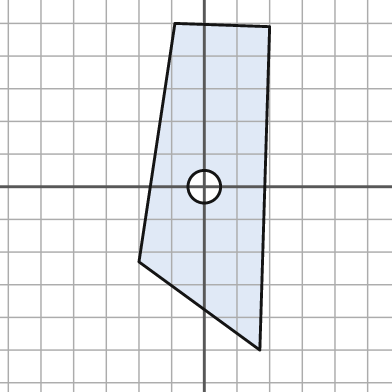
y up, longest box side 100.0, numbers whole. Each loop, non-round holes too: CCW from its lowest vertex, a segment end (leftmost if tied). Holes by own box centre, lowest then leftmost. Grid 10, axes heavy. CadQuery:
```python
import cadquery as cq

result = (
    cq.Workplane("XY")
    .moveTo(17.0, -50.0)
    .lineTo(20.0, 49.0)
    .lineTo(-9.0, 50.0)
    .lineTo(-20.0, -23.0)
    .close()
    .moveTo(0.0, 0.0)
    .circle(5.0)
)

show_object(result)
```